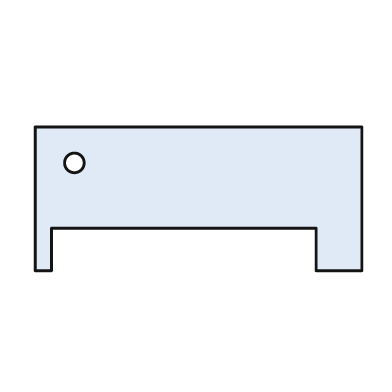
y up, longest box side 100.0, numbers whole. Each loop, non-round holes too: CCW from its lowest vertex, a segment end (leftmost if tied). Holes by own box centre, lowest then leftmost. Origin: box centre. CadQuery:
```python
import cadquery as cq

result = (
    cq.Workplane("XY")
    .moveTo(-50.0, -22.0)
    .lineTo(-45.0, -22.0)
    .lineTo(-45.0, -9.0)
    .lineTo(36.0, -9.0)
    .lineTo(36.0, -22.0)
    .lineTo(50.0, -22.0)
    .lineTo(50.0, 22.0)
    .lineTo(-50.0, 22.0)
    .close()
    .moveTo(-38.0, 11.0)
    .circle(3.0)
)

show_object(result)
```